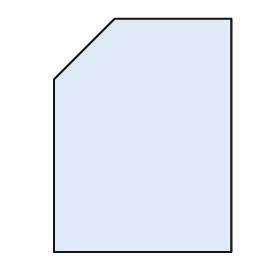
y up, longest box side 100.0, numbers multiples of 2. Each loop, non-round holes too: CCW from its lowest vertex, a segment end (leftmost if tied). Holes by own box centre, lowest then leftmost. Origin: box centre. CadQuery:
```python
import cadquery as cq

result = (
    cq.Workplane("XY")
    .moveTo(-38.0, -50.0)
    .lineTo(38.0, -50.0)
    .lineTo(38.0, 50.0)
    .lineTo(-12.0, 50.0)
    .lineTo(-38.0, 24.0)
    .close()
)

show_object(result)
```